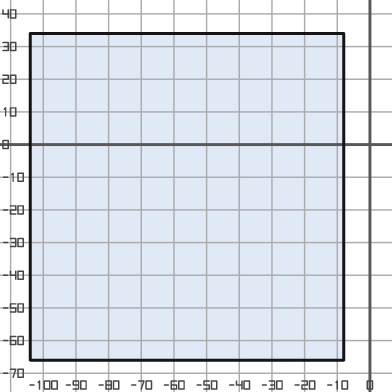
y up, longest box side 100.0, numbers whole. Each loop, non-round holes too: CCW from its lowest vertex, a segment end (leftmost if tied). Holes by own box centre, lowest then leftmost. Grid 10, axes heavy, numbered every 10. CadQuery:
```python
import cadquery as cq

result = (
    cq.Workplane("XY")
    .moveTo(-104.0, -66.0)
    .lineTo(-8.0, -66.0)
    .lineTo(-8.0, 34.0)
    .lineTo(-104.0, 34.0)
    .close()
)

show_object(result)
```